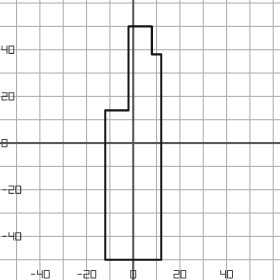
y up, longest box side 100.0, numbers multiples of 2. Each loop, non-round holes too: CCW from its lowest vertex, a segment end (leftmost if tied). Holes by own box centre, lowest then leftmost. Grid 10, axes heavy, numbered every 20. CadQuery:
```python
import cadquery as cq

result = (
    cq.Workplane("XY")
    .moveTo(-12.0, -50.0)
    .lineTo(12.0, -50.0)
    .lineTo(12.0, 38.0)
    .lineTo(8.0, 38.0)
    .lineTo(8.0, 50.0)
    .lineTo(-2.0, 50.0)
    .lineTo(-2.0, 14.0)
    .lineTo(-12.0, 14.0)
    .close()
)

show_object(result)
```